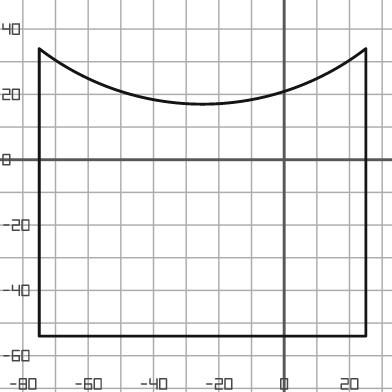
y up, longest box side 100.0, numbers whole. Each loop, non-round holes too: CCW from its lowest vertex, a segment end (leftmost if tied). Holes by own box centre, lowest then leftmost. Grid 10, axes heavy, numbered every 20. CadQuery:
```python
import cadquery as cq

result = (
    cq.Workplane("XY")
    .moveTo(-75.0, -54.0)
    .lineTo(25.0, -54.0)
    .lineTo(25.0, 34.0)
    .threePointArc((-25.0, 17.0), (-75.0, 34.0))
    .close()
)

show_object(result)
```